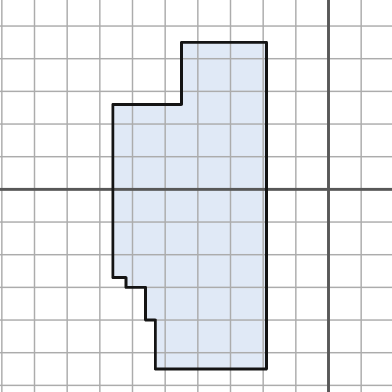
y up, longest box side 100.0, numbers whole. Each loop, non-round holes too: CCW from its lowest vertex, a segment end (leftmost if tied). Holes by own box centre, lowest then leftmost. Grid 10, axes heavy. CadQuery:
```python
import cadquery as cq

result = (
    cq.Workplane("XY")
    .moveTo(-53.0, -55.0)
    .lineTo(-19.0, -55.0)
    .lineTo(-19.0, 45.0)
    .lineTo(-45.0, 45.0)
    .lineTo(-45.0, 26.0)
    .lineTo(-66.0, 26.0)
    .lineTo(-66.0, -27.0)
    .lineTo(-62.0, -27.0)
    .lineTo(-62.0, -30.0)
    .lineTo(-56.0, -30.0)
    .lineTo(-56.0, -40.0)
    .lineTo(-53.0, -40.0)
    .close()
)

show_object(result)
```